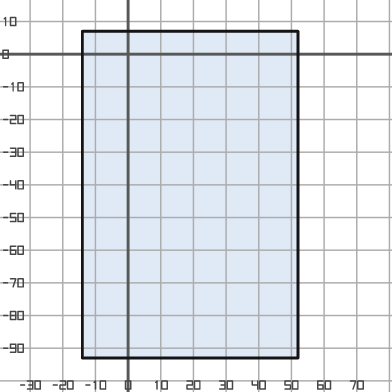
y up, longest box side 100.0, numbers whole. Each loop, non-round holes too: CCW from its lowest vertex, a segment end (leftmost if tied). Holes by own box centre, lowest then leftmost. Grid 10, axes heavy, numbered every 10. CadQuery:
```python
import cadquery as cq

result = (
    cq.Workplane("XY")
    .moveTo(-14.0, -93.0)
    .lineTo(52.0, -93.0)
    .lineTo(52.0, 7.0)
    .lineTo(-14.0, 7.0)
    .close()
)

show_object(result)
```